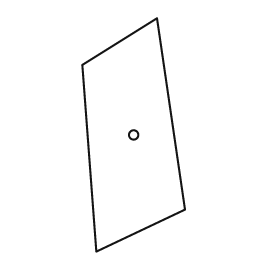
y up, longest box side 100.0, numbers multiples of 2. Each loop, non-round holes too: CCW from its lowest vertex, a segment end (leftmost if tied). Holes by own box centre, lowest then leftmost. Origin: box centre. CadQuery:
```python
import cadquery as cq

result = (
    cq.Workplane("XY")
    .moveTo(-16.0, -50.0)
    .lineTo(22.0, -32.0)
    .lineTo(10.0, 50.0)
    .lineTo(-22.0, 30.0)
    .close()
    .moveTo(0.0, 0.0)
    .circle(2.0)
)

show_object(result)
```